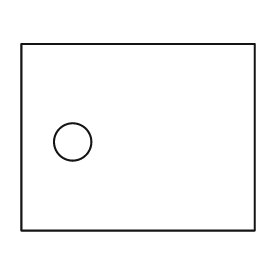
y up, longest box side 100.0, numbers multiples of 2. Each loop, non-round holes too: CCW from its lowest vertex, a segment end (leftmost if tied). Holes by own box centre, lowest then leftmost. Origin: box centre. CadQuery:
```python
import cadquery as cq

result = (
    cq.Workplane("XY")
    .moveTo(-50.0, -40.0)
    .lineTo(50.0, -40.0)
    .lineTo(50.0, 40.0)
    .lineTo(-50.0, 40.0)
    .close()
    .moveTo(-28.0, -2.0)
    .circle(8.0)
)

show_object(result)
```